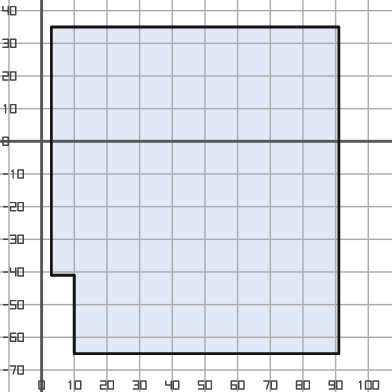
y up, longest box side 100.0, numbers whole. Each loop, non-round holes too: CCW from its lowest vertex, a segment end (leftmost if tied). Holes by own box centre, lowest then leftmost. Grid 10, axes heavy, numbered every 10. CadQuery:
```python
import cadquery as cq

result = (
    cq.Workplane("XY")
    .moveTo(10.0, -65.0)
    .lineTo(91.0, -65.0)
    .lineTo(91.0, 35.0)
    .lineTo(3.0, 35.0)
    .lineTo(3.0, -41.0)
    .lineTo(10.0, -41.0)
    .close()
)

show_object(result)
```